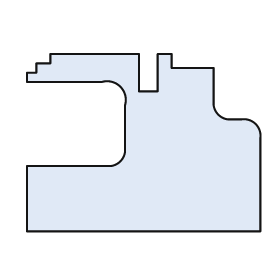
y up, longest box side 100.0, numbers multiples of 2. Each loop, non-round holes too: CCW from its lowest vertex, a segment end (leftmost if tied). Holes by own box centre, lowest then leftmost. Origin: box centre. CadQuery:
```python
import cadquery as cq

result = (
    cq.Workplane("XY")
    .moveTo(-50.0, -38.0)
    .lineTo(50.0, -38.0)
    .lineTo(50.0, 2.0)
    .threePointArc((48.0, 8.0), (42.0, 10.0))
    .lineTo(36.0, 10.0)
    .threePointArc((32.0, 12.0), (30.0, 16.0))
    .lineTo(30.0, 32.0)
    .lineTo(12.0, 32.0)
    .lineTo(12.0, 38.0)
    .lineTo(6.0, 38.0)
    .lineTo(6.0, 22.0)
    .lineTo(-2.0, 22.0)
    .lineTo(-2.0, 38.0)
    .lineTo(-40.0, 38.0)
    .lineTo(-40.0, 34.0)
    .lineTo(-46.0, 34.0)
    .lineTo(-46.0, 30.0)
    .lineTo(-50.0, 30.0)
    .lineTo(-50.0, 26.0)
    .lineTo(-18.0, 26.0)
    .threePointArc((-10.0, 24.0), (-8.0, 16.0))
    .lineTo(-8.0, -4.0)
    .threePointArc((-10.0, -8.0), (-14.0, -10.0))
    .lineTo(-50.0, -10.0)
    .close()
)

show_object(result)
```